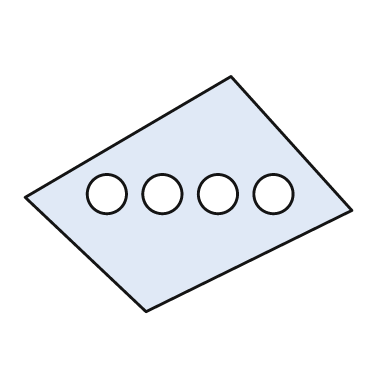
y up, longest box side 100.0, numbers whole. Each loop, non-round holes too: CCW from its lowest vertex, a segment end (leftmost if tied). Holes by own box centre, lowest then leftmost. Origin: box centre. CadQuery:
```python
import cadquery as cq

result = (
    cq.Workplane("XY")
    .moveTo(-13.0, -36.0)
    .lineTo(50.0, -5.0)
    .lineTo(13.0, 36.0)
    .lineTo(-50.0, -1.0)
    .close()
    .moveTo(-25.0, 0.0)
    .circle(6.0)
    .moveTo(-8.0, 0.0)
    .circle(6.0)
    .moveTo(9.0, 0.0)
    .circle(6.0)
    .moveTo(26.0, 0.0)
    .circle(6.0)
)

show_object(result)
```